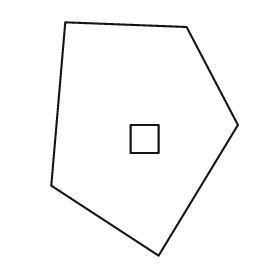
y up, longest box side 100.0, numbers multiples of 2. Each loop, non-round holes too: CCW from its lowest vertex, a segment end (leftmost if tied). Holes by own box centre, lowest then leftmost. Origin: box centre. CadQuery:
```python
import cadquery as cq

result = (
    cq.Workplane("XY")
    .moveTo(6.0, -50.0)
    .lineTo(40.0, 6.0)
    .lineTo(18.0, 48.0)
    .lineTo(-34.0, 50.0)
    .lineTo(-40.0, -20.0)
    .close()
    .moveTo(-6.0, -6.0)
    .lineTo(6.0, -6.0)
    .lineTo(6.0, 6.0)
    .lineTo(-6.0, 6.0)
    .close()
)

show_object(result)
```